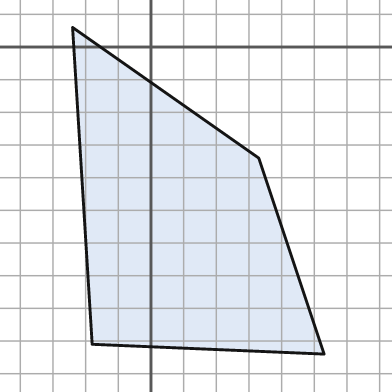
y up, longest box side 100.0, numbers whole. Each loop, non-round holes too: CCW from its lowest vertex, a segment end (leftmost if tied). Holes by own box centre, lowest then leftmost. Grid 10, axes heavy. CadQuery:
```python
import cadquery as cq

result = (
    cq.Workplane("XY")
    .moveTo(53.0, -94.0)
    .lineTo(33.0, -34.0)
    .lineTo(-24.0, 6.0)
    .lineTo(-18.0, -91.0)
    .close()
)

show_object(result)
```